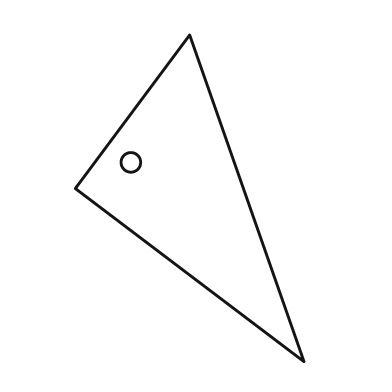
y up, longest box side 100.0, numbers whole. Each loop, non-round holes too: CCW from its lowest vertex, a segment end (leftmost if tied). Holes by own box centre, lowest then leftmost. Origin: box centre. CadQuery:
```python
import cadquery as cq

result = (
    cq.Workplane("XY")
    .moveTo(35.0, -50.0)
    .lineTo(0.0, 50.0)
    .lineTo(-35.0, 3.0)
    .close()
    .moveTo(-18.0, 11.0)
    .circle(3.0)
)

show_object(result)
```